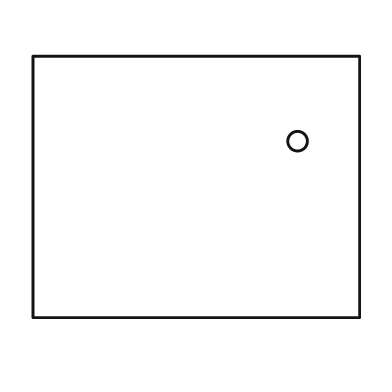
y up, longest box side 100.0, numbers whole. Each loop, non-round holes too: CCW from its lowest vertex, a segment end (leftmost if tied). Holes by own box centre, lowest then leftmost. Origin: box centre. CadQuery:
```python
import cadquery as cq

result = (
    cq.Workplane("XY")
    .moveTo(-50.0, -40.0)
    .lineTo(50.0, -40.0)
    .lineTo(50.0, 40.0)
    .lineTo(-50.0, 40.0)
    .close()
    .moveTo(31.0, 14.0)
    .circle(3.0)
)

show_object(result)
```